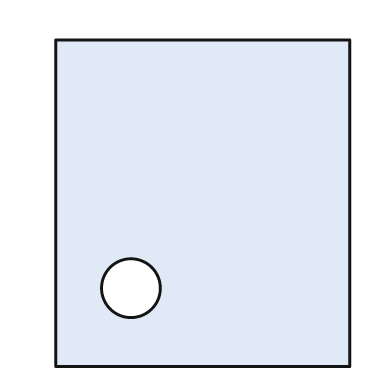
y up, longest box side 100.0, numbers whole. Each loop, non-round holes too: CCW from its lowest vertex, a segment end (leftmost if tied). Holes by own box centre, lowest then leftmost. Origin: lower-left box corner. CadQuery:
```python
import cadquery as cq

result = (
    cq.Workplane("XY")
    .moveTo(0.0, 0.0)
    .lineTo(90.0, 0.0)
    .lineTo(90.0, 100.0)
    .lineTo(0.0, 100.0)
    .close()
    .moveTo(23.0, 24.0)
    .circle(9.0)
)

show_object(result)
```